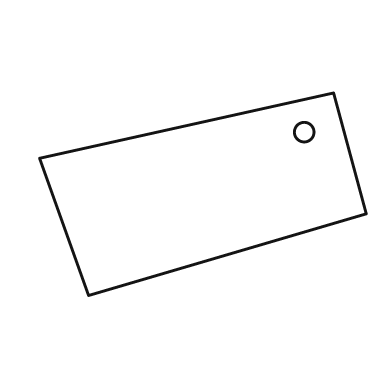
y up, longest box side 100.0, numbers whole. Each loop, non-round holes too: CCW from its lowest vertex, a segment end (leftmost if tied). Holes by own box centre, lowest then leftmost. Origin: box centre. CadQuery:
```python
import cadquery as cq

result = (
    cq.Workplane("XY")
    .moveTo(-35.0, -31.0)
    .lineTo(50.0, -6.0)
    .lineTo(40.0, 31.0)
    .lineTo(-50.0, 11.0)
    .close()
    .moveTo(31.0, 19.0)
    .circle(3.0)
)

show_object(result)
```